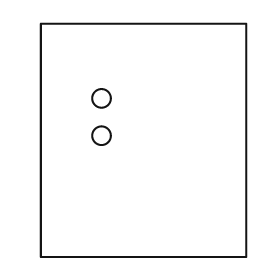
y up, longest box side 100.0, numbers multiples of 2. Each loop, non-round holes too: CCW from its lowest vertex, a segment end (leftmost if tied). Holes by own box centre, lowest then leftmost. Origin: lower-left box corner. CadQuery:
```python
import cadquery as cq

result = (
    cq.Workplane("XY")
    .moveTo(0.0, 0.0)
    .lineTo(88.0, 0.0)
    .lineTo(88.0, 100.0)
    .lineTo(0.0, 100.0)
    .close()
    .moveTo(26.0, 52.0)
    .circle(4.0)
    .moveTo(26.0, 68.0)
    .circle(4.0)
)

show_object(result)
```